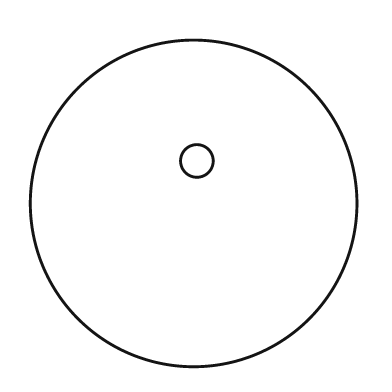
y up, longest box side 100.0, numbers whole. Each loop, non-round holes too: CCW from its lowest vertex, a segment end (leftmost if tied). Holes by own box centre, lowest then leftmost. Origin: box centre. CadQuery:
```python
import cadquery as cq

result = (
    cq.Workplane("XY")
    .moveTo(0.0, 0.0)
    .circle(50.0)
    .moveTo(1.0, 13.0)
    .circle(5.0)
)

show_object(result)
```